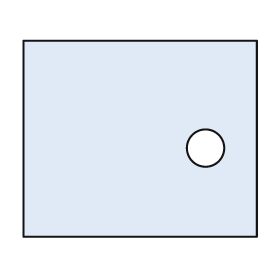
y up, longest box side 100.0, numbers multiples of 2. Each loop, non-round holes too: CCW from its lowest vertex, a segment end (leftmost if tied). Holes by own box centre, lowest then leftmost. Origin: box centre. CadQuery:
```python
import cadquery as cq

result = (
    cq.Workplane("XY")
    .moveTo(-50.0, -42.0)
    .lineTo(50.0, -42.0)
    .lineTo(50.0, 42.0)
    .lineTo(-50.0, 42.0)
    .close()
    .moveTo(28.0, -4.0)
    .circle(8.0)
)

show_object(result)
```